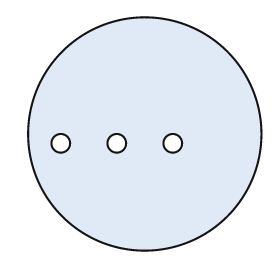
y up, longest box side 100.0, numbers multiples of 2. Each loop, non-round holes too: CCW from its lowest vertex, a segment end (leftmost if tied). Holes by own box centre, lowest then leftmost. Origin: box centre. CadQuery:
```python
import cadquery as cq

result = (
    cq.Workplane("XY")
    .moveTo(0.0, 0.0)
    .circle(50.0)
    .moveTo(-36.0, -4.0)
    .circle(4.0)
    .moveTo(-12.0, -4.0)
    .circle(4.0)
    .moveTo(12.0, -4.0)
    .circle(4.0)
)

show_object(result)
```